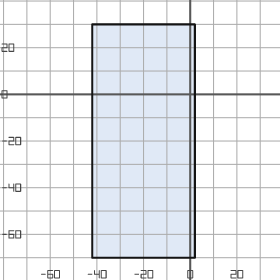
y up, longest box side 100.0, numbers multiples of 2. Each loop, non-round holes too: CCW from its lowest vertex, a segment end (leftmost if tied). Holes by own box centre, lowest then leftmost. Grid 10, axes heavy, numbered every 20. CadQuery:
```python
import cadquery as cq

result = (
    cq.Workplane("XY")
    .moveTo(-42.0, -70.0)
    .lineTo(2.0, -70.0)
    .lineTo(2.0, 30.0)
    .lineTo(-42.0, 30.0)
    .close()
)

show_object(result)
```